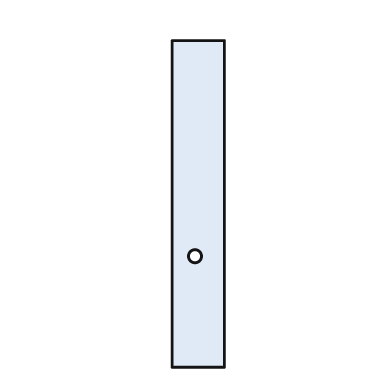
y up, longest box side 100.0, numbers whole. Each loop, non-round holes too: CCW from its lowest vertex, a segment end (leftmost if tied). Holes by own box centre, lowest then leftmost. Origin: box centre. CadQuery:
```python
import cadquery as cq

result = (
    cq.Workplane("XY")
    .moveTo(-8.0, -50.0)
    .lineTo(8.0, -50.0)
    .lineTo(8.0, 50.0)
    .lineTo(-8.0, 50.0)
    .close()
    .moveTo(-1.0, -16.0)
    .circle(2.0)
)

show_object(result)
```